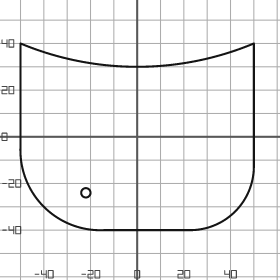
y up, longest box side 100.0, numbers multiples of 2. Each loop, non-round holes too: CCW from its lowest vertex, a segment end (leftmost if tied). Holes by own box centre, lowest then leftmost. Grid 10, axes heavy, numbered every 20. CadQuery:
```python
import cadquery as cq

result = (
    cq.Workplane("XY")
    .moveTo(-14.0, -40.0)
    .lineTo(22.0, -40.0)
    .threePointArc((42.0, -32.0), (50.0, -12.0))
    .lineTo(50.0, 40.0)
    .threePointArc((0.0, 30.0), (-50.0, 40.0))
    .lineTo(-50.0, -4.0)
    .threePointArc((-40.0, -30.0), (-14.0, -40.0))
    .close()
    .moveTo(-22.0, -24.0)
    .circle(2.0)
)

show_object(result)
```